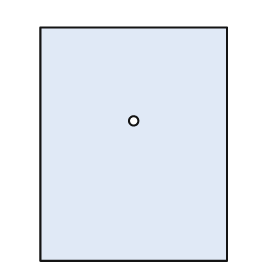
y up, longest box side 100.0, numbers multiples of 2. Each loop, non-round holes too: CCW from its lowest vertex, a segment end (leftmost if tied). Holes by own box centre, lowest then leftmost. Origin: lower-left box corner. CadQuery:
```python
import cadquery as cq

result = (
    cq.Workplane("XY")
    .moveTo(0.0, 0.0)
    .lineTo(80.0, 0.0)
    .lineTo(80.0, 100.0)
    .lineTo(0.0, 100.0)
    .close()
    .moveTo(40.0, 60.0)
    .circle(2.0)
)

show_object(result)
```